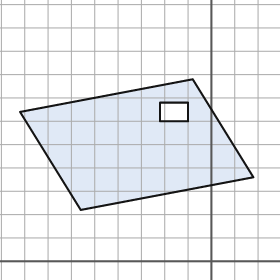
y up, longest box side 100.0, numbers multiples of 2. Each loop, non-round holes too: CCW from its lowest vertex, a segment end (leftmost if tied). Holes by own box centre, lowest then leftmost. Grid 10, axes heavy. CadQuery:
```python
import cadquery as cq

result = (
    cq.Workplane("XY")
    .moveTo(-56.0, 22.0)
    .lineTo(18.0, 36.0)
    .lineTo(-8.0, 78.0)
    .lineTo(-82.0, 64.0)
    .close()
    .moveTo(-22.0, 60.0)
    .lineTo(-10.0, 60.0)
    .lineTo(-10.0, 68.0)
    .lineTo(-22.0, 68.0)
    .close()
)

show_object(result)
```